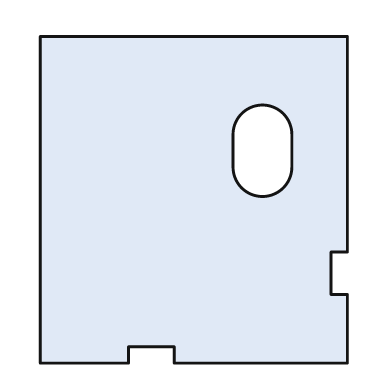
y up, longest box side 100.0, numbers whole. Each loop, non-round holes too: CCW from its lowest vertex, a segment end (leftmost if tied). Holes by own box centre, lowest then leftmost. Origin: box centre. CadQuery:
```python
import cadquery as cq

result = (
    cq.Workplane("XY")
    .moveTo(-47.0, -50.0)
    .lineTo(-20.0, -50.0)
    .lineTo(-20.0, -45.0)
    .lineTo(-6.0, -45.0)
    .lineTo(-6.0, -50.0)
    .lineTo(47.0, -50.0)
    .lineTo(47.0, -29.0)
    .lineTo(42.0, -29.0)
    .lineTo(42.0, -16.0)
    .lineTo(47.0, -16.0)
    .lineTo(47.0, 50.0)
    .lineTo(-47.0, 50.0)
    .close()
    .moveTo(12.0, 10.0)
    .threePointArc((21.0, 1.0), (30.0, 10.0))
    .lineTo(30.0, 20.0)
    .threePointArc((21.0, 29.0), (12.0, 20.0))
    .close()
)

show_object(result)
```